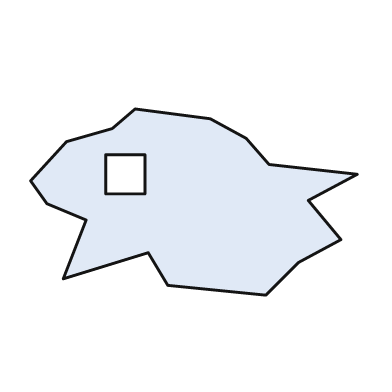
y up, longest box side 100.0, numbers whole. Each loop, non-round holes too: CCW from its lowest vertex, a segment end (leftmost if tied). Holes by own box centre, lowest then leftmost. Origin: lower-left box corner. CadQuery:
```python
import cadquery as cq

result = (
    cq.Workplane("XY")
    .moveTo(72.0, 0.0)
    .lineTo(82.0, 10.0)
    .lineTo(95.0, 17.0)
    .lineTo(85.0, 29.0)
    .lineTo(100.0, 37.0)
    .lineTo(73.0, 40.0)
    .lineTo(66.0, 48.0)
    .lineTo(55.0, 54.0)
    .lineTo(32.0, 57.0)
    .lineTo(25.0, 51.0)
    .lineTo(11.0, 47.0)
    .lineTo(0.0, 35.0)
    .lineTo(5.0, 28.0)
    .lineTo(17.0, 23.0)
    .lineTo(10.0, 5.0)
    .lineTo(36.0, 13.0)
    .lineTo(42.0, 3.0)
    .close()
    .moveTo(23.0, 31.0)
    .lineTo(35.0, 31.0)
    .lineTo(35.0, 43.0)
    .lineTo(23.0, 43.0)
    .close()
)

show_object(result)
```